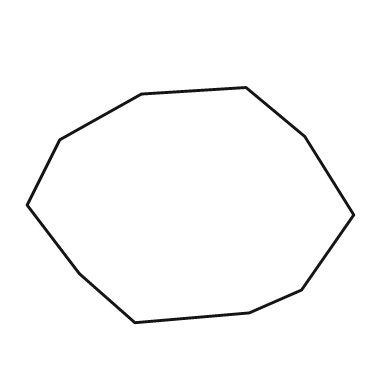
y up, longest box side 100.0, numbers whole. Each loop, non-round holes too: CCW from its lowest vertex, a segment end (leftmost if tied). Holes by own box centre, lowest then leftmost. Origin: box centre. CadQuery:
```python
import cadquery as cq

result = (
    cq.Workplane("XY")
    .moveTo(-17.0, -36.0)
    .lineTo(18.0, -33.0)
    .lineTo(34.0, -26.0)
    .lineTo(50.0, -3.0)
    .lineTo(35.0, 21.0)
    .lineTo(17.0, 36.0)
    .lineTo(-15.0, 34.0)
    .lineTo(-40.0, 20.0)
    .lineTo(-50.0, 0.0)
    .lineTo(-34.0, -21.0)
    .close()
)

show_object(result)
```